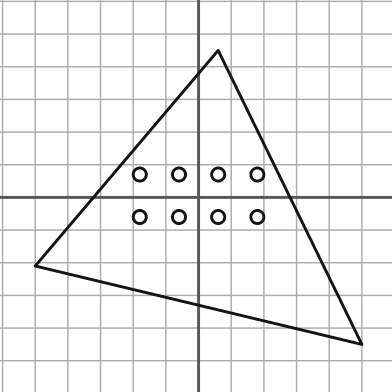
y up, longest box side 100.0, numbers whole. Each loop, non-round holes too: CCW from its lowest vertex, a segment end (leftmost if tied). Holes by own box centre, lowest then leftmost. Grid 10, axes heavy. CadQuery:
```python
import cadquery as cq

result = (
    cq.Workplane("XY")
    .moveTo(50.0, -45.0)
    .lineTo(6.0, 45.0)
    .lineTo(-50.0, -21.0)
    .close()
    .moveTo(-18.0, -6.0)
    .circle(2.0)
    .moveTo(-6.0, -6.0)
    .circle(2.0)
    .moveTo(6.0, -6.0)
    .circle(2.0)
    .moveTo(18.0, -6.0)
    .circle(2.0)
    .moveTo(-18.0, 7.0)
    .circle(2.0)
    .moveTo(-6.0, 7.0)
    .circle(2.0)
    .moveTo(6.0, 7.0)
    .circle(2.0)
    .moveTo(18.0, 7.0)
    .circle(2.0)
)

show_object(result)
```